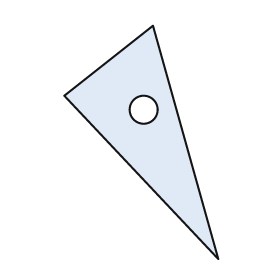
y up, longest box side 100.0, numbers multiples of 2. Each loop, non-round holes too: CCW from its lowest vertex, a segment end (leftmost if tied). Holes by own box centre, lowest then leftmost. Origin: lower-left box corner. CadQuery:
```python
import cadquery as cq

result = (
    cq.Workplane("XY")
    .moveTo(66.0, 0.0)
    .lineTo(38.0, 100.0)
    .lineTo(0.0, 70.0)
    .close()
    .moveTo(34.0, 64.0)
    .circle(6.0)
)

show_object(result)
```